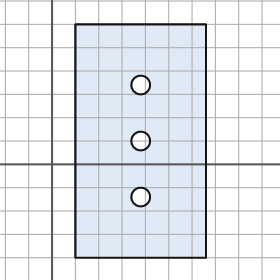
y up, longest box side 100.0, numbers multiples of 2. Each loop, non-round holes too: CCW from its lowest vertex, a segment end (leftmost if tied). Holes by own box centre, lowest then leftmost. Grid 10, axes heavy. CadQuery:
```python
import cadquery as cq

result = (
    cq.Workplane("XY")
    .moveTo(10.0, -40.0)
    .lineTo(66.0, -40.0)
    .lineTo(66.0, 60.0)
    .lineTo(10.0, 60.0)
    .close()
    .moveTo(38.0, -14.0)
    .circle(4.0)
    .moveTo(38.0, 10.0)
    .circle(4.0)
    .moveTo(38.0, 34.0)
    .circle(4.0)
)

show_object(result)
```